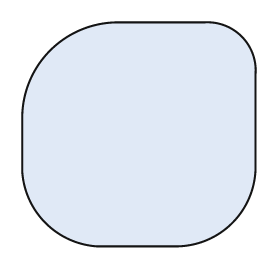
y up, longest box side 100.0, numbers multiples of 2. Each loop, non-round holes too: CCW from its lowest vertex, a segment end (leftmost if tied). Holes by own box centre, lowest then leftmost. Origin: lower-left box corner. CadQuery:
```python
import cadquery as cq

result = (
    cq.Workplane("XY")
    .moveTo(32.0, 0.0)
    .lineTo(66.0, 0.0)
    .threePointArc((90.0, 10.0), (100.0, 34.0))
    .lineTo(100.0, 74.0)
    .threePointArc((94.0, 90.0), (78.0, 96.0))
    .lineTo(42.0, 96.0)
    .threePointArc((12.0, 84.0), (0.0, 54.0))
    .lineTo(0.0, 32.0)
    .threePointArc((10.0, 10.0), (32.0, 0.0))
    .close()
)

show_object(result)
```